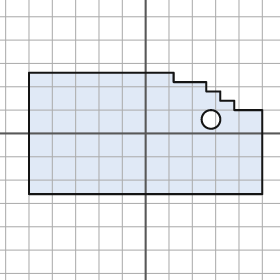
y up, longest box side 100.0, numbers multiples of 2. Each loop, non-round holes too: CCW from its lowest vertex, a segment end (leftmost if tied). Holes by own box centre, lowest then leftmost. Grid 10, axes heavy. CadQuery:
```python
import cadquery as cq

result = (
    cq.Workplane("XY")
    .moveTo(-50.0, -26.0)
    .lineTo(50.0, -26.0)
    .lineTo(50.0, 10.0)
    .lineTo(38.0, 10.0)
    .lineTo(38.0, 14.0)
    .lineTo(32.0, 14.0)
    .lineTo(32.0, 18.0)
    .lineTo(26.0, 18.0)
    .lineTo(26.0, 22.0)
    .lineTo(12.0, 22.0)
    .lineTo(12.0, 26.0)
    .lineTo(-50.0, 26.0)
    .close()
    .moveTo(28.0, 6.0)
    .circle(4.0)
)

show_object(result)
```